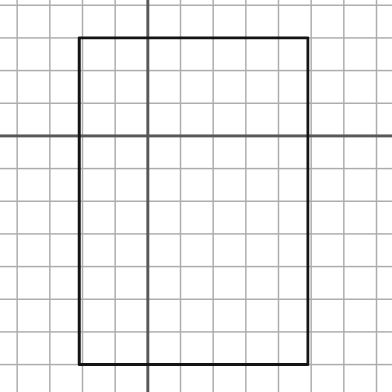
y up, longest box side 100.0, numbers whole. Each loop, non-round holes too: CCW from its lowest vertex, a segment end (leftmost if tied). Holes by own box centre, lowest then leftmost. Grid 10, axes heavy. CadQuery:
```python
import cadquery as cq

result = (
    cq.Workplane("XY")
    .moveTo(-21.0, -70.0)
    .lineTo(49.0, -70.0)
    .lineTo(49.0, 30.0)
    .lineTo(-21.0, 30.0)
    .close()
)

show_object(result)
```